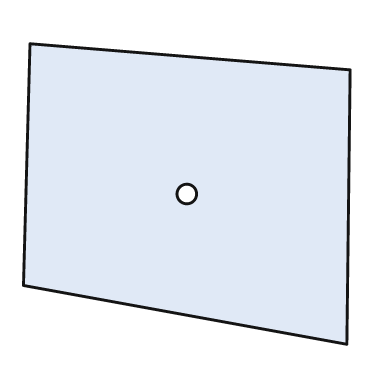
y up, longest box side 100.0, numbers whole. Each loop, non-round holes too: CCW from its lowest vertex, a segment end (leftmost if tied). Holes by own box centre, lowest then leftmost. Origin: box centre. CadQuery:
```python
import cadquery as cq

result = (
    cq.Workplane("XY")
    .moveTo(49.0, -46.0)
    .lineTo(50.0, 38.0)
    .lineTo(-48.0, 46.0)
    .lineTo(-50.0, -28.0)
    .close()
    .moveTo(0.0, 0.0)
    .circle(3.0)
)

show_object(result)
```